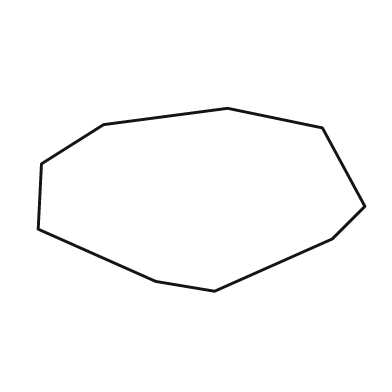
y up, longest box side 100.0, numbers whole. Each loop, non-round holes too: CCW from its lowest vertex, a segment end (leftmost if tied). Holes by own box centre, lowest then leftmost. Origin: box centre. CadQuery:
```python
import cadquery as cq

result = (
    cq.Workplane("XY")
    .moveTo(4.0, -28.0)
    .lineTo(40.0, -12.0)
    .lineTo(50.0, -2.0)
    .lineTo(37.0, 22.0)
    .lineTo(8.0, 28.0)
    .lineTo(-30.0, 23.0)
    .lineTo(-49.0, 11.0)
    .lineTo(-50.0, -9.0)
    .lineTo(-14.0, -25.0)
    .close()
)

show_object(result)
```